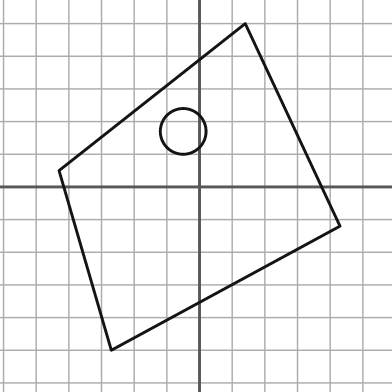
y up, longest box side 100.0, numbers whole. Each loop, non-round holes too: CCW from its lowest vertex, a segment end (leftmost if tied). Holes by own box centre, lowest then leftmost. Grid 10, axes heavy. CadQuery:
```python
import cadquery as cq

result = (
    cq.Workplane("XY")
    .moveTo(-27.0, -50.0)
    .lineTo(43.0, -12.0)
    .lineTo(14.0, 50.0)
    .lineTo(-43.0, 5.0)
    .close()
    .moveTo(-5.0, 17.0)
    .circle(7.0)
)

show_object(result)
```